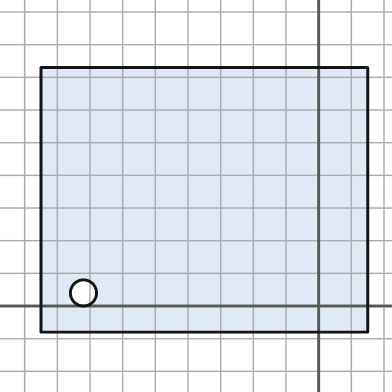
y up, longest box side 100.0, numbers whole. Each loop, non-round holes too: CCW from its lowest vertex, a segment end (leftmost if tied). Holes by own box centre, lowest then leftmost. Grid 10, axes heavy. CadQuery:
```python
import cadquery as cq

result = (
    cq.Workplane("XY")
    .moveTo(-85.0, -8.0)
    .lineTo(15.0, -8.0)
    .lineTo(15.0, 73.0)
    .lineTo(-85.0, 73.0)
    .close()
    .moveTo(-72.0, 4.0)
    .circle(4.0)
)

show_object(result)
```